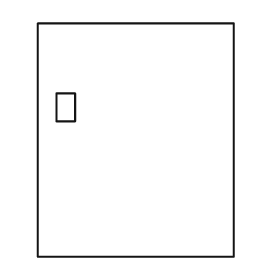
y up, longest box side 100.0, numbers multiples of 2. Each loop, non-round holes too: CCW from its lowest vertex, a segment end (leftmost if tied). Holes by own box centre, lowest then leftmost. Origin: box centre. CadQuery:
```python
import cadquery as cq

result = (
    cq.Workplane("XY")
    .moveTo(-42.0, -50.0)
    .lineTo(42.0, -50.0)
    .lineTo(42.0, 50.0)
    .lineTo(-42.0, 50.0)
    .close()
    .moveTo(-34.0, 8.0)
    .lineTo(-26.0, 8.0)
    .lineTo(-26.0, 20.0)
    .lineTo(-34.0, 20.0)
    .close()
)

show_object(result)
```